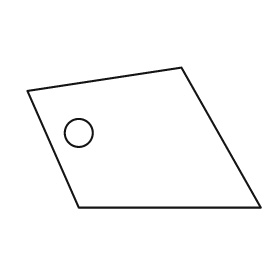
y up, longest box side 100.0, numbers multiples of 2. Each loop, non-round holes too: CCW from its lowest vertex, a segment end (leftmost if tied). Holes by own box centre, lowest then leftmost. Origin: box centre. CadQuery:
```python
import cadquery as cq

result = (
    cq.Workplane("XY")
    .moveTo(-28.0, -30.0)
    .lineTo(50.0, -30.0)
    .lineTo(16.0, 30.0)
    .lineTo(-50.0, 20.0)
    .close()
    .moveTo(-28.0, 2.0)
    .circle(6.0)
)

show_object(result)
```